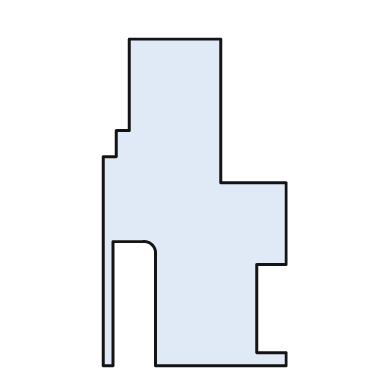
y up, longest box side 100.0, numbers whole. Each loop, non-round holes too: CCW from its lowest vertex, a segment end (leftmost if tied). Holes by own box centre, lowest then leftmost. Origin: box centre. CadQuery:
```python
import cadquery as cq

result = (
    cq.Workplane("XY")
    .moveTo(-28.0, -50.0)
    .lineTo(-25.0, -50.0)
    .lineTo(-25.0, -12.0)
    .lineTo(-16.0, -12.0)
    .threePointArc((-13.0, -13.0), (-12.0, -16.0))
    .lineTo(-12.0, -50.0)
    .lineTo(28.0, -50.0)
    .lineTo(28.0, -46.0)
    .lineTo(19.0, -46.0)
    .lineTo(19.0, -19.0)
    .lineTo(28.0, -19.0)
    .lineTo(28.0, 6.0)
    .lineTo(8.0, 6.0)
    .lineTo(8.0, 50.0)
    .lineTo(-20.0, 50.0)
    .lineTo(-20.0, 22.0)
    .lineTo(-24.0, 22.0)
    .lineTo(-24.0, 14.0)
    .lineTo(-28.0, 14.0)
    .close()
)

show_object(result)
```